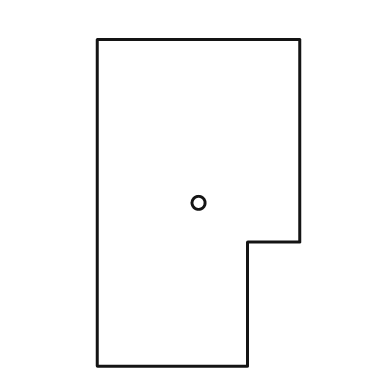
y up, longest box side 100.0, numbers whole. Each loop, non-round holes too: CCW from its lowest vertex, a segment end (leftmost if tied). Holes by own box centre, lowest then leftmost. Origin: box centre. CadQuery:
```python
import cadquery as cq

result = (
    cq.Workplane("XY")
    .moveTo(-31.0, -50.0)
    .lineTo(15.0, -50.0)
    .lineTo(15.0, -12.0)
    .lineTo(31.0, -12.0)
    .lineTo(31.0, 50.0)
    .lineTo(-31.0, 50.0)
    .close()
    .moveTo(0.0, 0.0)
    .circle(2.0)
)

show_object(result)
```